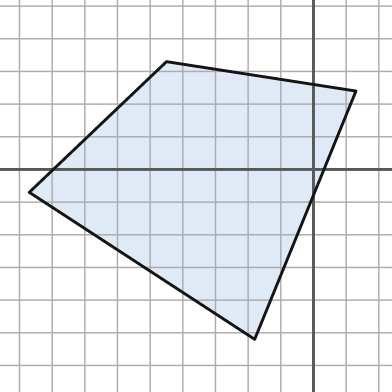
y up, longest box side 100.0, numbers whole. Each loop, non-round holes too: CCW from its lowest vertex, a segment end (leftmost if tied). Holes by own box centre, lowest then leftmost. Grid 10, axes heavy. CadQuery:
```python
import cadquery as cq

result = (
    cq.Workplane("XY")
    .moveTo(-18.0, -52.0)
    .lineTo(13.0, 24.0)
    .lineTo(-45.0, 33.0)
    .lineTo(-87.0, -7.0)
    .close()
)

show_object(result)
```